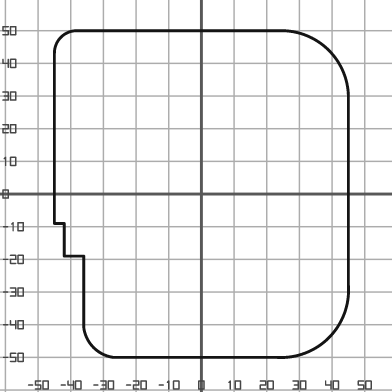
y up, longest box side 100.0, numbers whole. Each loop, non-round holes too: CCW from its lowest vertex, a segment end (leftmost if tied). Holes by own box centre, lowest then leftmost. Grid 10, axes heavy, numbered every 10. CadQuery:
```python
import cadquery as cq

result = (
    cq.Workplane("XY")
    .moveTo(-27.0, -50.0)
    .lineTo(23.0, -50.0)
    .threePointArc((39.0, -44.0), (45.0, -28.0))
    .lineTo(45.0, 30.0)
    .threePointArc((39.0, 44.0), (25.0, 50.0))
    .lineTo(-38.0, 50.0)
    .threePointArc((-43.0, 48.0), (-45.0, 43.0))
    .lineTo(-45.0, -9.0)
    .lineTo(-42.0, -9.0)
    .lineTo(-42.0, -19.0)
    .lineTo(-36.0, -19.0)
    .lineTo(-36.0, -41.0)
    .threePointArc((-33.0, -47.0), (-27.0, -50.0))
    .close()
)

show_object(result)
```